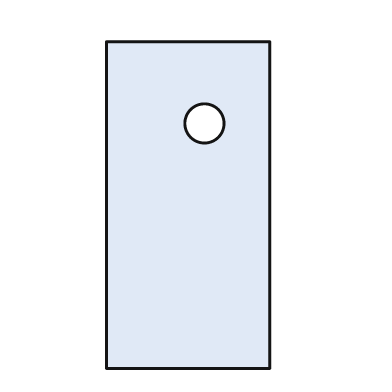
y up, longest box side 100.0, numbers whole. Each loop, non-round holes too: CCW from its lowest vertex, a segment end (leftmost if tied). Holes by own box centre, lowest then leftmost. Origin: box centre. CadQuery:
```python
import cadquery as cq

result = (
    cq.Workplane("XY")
    .moveTo(-25.0, -50.0)
    .lineTo(25.0, -50.0)
    .lineTo(25.0, 50.0)
    .lineTo(-25.0, 50.0)
    .close()
    .moveTo(5.0, 25.0)
    .circle(6.0)
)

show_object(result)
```